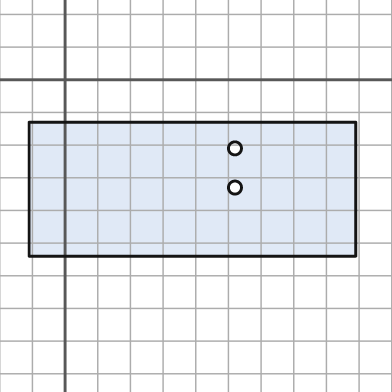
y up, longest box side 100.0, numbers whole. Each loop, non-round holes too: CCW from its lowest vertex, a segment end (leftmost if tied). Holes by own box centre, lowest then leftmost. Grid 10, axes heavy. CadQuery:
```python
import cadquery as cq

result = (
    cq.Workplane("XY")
    .moveTo(-11.0, -54.0)
    .lineTo(89.0, -54.0)
    .lineTo(89.0, -13.0)
    .lineTo(-11.0, -13.0)
    .close()
    .moveTo(52.0, -33.0)
    .circle(2.0)
    .moveTo(52.0, -21.0)
    .circle(2.0)
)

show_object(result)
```